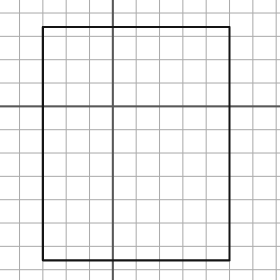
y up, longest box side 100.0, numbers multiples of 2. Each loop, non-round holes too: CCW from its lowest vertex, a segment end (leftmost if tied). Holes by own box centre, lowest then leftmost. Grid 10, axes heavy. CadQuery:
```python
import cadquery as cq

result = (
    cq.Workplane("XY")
    .moveTo(-30.0, -66.0)
    .lineTo(50.0, -66.0)
    .lineTo(50.0, 34.0)
    .lineTo(-30.0, 34.0)
    .close()
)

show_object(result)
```